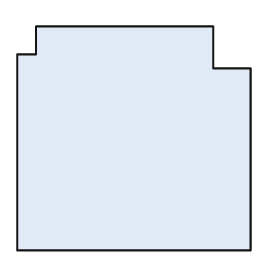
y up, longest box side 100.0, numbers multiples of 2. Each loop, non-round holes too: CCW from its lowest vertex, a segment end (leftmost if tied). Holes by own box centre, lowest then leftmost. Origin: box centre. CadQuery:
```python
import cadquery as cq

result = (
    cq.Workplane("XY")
    .moveTo(-50.0, -48.0)
    .lineTo(50.0, -48.0)
    .lineTo(50.0, 30.0)
    .lineTo(34.0, 30.0)
    .lineTo(34.0, 48.0)
    .lineTo(-42.0, 48.0)
    .lineTo(-42.0, 36.0)
    .lineTo(-50.0, 36.0)
    .close()
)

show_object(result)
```